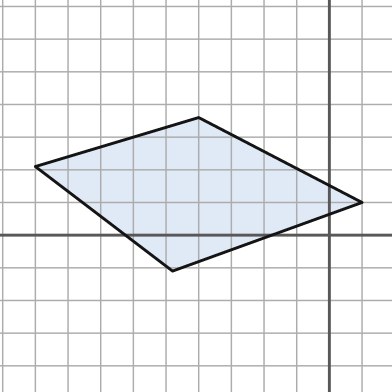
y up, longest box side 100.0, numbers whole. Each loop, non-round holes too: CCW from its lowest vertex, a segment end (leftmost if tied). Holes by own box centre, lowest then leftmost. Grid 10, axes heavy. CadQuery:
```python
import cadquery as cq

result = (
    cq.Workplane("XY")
    .moveTo(-48.0, -11.0)
    .lineTo(10.0, 10.0)
    .lineTo(-40.0, 36.0)
    .lineTo(-90.0, 21.0)
    .close()
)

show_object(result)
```